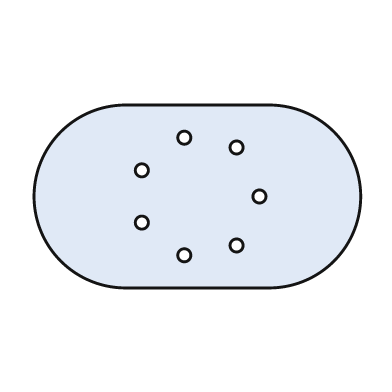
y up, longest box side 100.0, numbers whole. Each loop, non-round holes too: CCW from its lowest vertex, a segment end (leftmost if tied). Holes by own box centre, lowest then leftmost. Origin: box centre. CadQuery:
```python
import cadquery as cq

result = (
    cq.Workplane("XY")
    .moveTo(-22.0, -28.0)
    .lineTo(22.0, -28.0)
    .threePointArc((50.0, 0.0), (22.0, 28.0))
    .lineTo(-22.0, 28.0)
    .threePointArc((-50.0, 0.0), (-22.0, -28.0))
    .close()
    .moveTo(-4.0, -18.0)
    .circle(2.0)
    .moveTo(12.0, -15.0)
    .circle(2.0)
    .moveTo(-17.0, -8.0)
    .circle(2.0)
    .moveTo(19.0, 0.0)
    .circle(2.0)
    .moveTo(-17.0, 8.0)
    .circle(2.0)
    .moveTo(12.0, 15.0)
    .circle(2.0)
    .moveTo(-4.0, 18.0)
    .circle(2.0)
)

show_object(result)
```